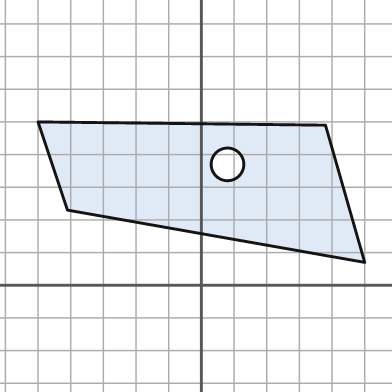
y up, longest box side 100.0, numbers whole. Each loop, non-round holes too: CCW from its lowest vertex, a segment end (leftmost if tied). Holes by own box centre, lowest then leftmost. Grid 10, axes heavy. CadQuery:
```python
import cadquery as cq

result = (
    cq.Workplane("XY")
    .moveTo(50.0, 7.0)
    .lineTo(38.0, 49.0)
    .lineTo(-50.0, 50.0)
    .lineTo(-41.0, 23.0)
    .close()
    .moveTo(8.0, 37.0)
    .circle(5.0)
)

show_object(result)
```